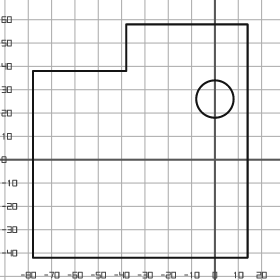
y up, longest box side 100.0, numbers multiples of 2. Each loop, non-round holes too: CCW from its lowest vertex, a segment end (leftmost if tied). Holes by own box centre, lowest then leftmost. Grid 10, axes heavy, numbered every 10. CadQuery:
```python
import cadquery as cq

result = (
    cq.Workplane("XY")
    .moveTo(-78.0, -42.0)
    .lineTo(14.0, -42.0)
    .lineTo(14.0, 58.0)
    .lineTo(-38.0, 58.0)
    .lineTo(-38.0, 38.0)
    .lineTo(-78.0, 38.0)
    .close()
    .moveTo(0.0, 26.0)
    .circle(8.0)
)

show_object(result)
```